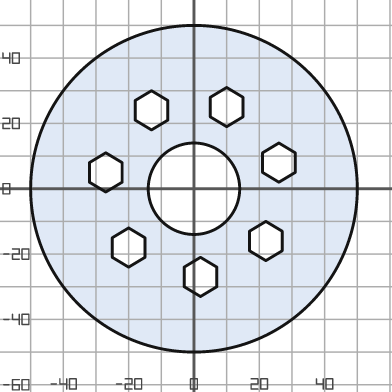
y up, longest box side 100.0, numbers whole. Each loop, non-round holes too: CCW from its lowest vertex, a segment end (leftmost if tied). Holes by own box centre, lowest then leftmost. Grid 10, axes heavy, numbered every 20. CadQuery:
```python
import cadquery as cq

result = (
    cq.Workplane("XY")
    .moveTo(0.0, 0.0)
    .circle(50.0)
    .moveTo(2.0, -33.0)
    .lineTo(7.0, -30.0)
    .lineTo(7.0, -24.0)
    .lineTo(2.0, -21.0)
    .lineTo(-3.0, -24.0)
    .lineTo(-3.0, -30.0)
    .close()
    .moveTo(-20.0, -24.0)
    .lineTo(-15.0, -21.0)
    .lineTo(-15.0, -15.0)
    .lineTo(-20.0, -12.0)
    .lineTo(-25.0, -15.0)
    .lineTo(-25.0, -21.0)
    .close()
    .moveTo(22.0, -22.0)
    .lineTo(27.0, -19.0)
    .lineTo(27.0, -13.0)
    .lineTo(22.0, -10.0)
    .lineTo(17.0, -13.0)
    .lineTo(17.0, -19.0)
    .close()
    .moveTo(0.0, 0.0)
    .circle(14.0)
    .moveTo(-27.0, -1.0)
    .lineTo(-22.0, 2.0)
    .lineTo(-22.0, 8.0)
    .lineTo(-27.0, 11.0)
    .lineTo(-32.0, 8.0)
    .lineTo(-32.0, 2.0)
    .close()
    .moveTo(26.0, 2.0)
    .lineTo(31.0, 5.0)
    .lineTo(31.0, 11.0)
    .lineTo(26.0, 14.0)
    .lineTo(21.0, 11.0)
    .lineTo(21.0, 5.0)
    .close()
    .moveTo(-13.0, 18.0)
    .lineTo(-8.0, 21.0)
    .lineTo(-8.0, 27.0)
    .lineTo(-13.0, 30.0)
    .lineTo(-18.0, 27.0)
    .lineTo(-18.0, 21.0)
    .close()
    .moveTo(10.0, 19.0)
    .lineTo(15.0, 22.0)
    .lineTo(15.0, 28.0)
    .lineTo(10.0, 31.0)
    .lineTo(5.0, 28.0)
    .lineTo(5.0, 22.0)
    .close()
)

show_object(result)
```